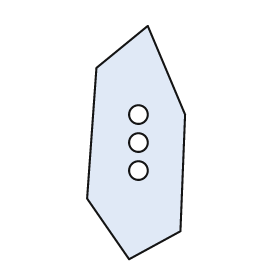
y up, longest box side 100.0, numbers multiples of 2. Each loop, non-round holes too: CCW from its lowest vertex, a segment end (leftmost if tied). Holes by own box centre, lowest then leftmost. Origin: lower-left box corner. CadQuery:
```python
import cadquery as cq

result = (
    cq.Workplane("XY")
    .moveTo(18.0, 0.0)
    .lineTo(40.0, 12.0)
    .lineTo(42.0, 62.0)
    .lineTo(26.0, 100.0)
    .lineTo(4.0, 82.0)
    .lineTo(0.0, 26.0)
    .close()
    .moveTo(22.0, 38.0)
    .circle(4.0)
    .moveTo(22.0, 50.0)
    .circle(4.0)
    .moveTo(22.0, 62.0)
    .circle(4.0)
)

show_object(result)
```